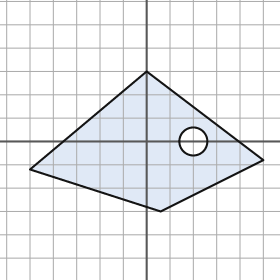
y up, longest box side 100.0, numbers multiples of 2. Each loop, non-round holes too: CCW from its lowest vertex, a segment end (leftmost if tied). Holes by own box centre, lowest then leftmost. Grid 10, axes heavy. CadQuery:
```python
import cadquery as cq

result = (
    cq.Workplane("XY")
    .moveTo(6.0, -30.0)
    .lineTo(50.0, -8.0)
    .lineTo(0.0, 30.0)
    .lineTo(-50.0, -12.0)
    .close()
    .moveTo(20.0, 0.0)
    .circle(6.0)
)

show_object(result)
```